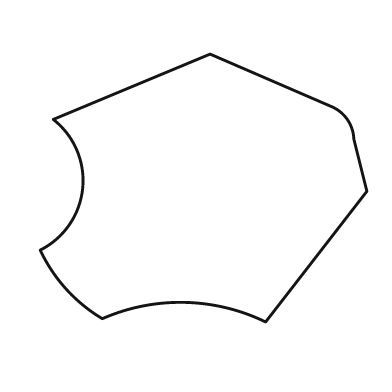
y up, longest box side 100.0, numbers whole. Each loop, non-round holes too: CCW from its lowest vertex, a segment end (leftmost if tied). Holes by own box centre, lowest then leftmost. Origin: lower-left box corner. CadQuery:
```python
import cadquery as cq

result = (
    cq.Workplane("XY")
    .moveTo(69.0, 0.0)
    .lineTo(100.0, 40.0)
    .lineTo(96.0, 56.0)
    .threePointArc((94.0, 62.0), (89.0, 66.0))
    .lineTo(52.0, 82.0)
    .lineTo(4.0, 62.0)
    .threePointArc((13.0, 41.0), (0.0, 22.0))
    .threePointArc((8.0, 10.0), (19.0, 1.0))
    .threePointArc((44.0, 6.0), (69.0, 0.0))
    .close()
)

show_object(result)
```